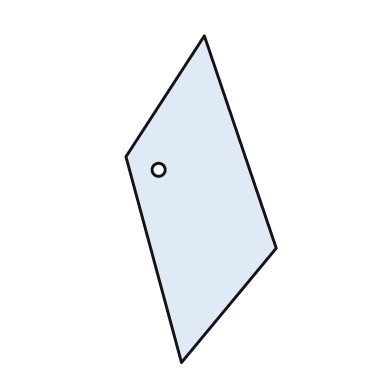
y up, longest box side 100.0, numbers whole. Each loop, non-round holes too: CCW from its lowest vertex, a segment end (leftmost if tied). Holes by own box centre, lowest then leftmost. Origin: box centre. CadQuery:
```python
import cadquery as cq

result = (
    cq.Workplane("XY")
    .moveTo(-6.0, -50.0)
    .lineTo(23.0, -15.0)
    .lineTo(1.0, 50.0)
    .lineTo(-23.0, 13.0)
    .close()
    .moveTo(-13.0, 9.0)
    .circle(2.0)
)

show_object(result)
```